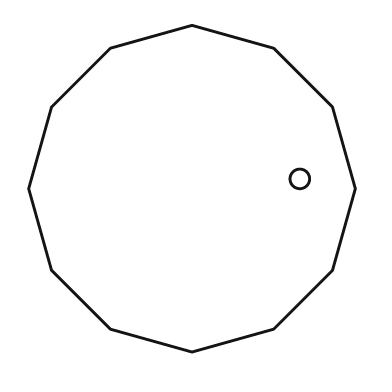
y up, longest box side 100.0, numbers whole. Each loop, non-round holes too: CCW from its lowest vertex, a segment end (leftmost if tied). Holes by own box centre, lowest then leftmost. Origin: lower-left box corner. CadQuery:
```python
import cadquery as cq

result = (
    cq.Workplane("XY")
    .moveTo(50.0, 0.0)
    .lineTo(75.0, 7.0)
    .lineTo(93.0, 25.0)
    .lineTo(100.0, 50.0)
    .lineTo(93.0, 75.0)
    .lineTo(75.0, 93.0)
    .lineTo(50.0, 100.0)
    .lineTo(25.0, 93.0)
    .lineTo(7.0, 75.0)
    .lineTo(0.0, 50.0)
    .lineTo(7.0, 25.0)
    .lineTo(25.0, 7.0)
    .close()
    .moveTo(83.0, 53.0)
    .circle(3.0)
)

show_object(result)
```